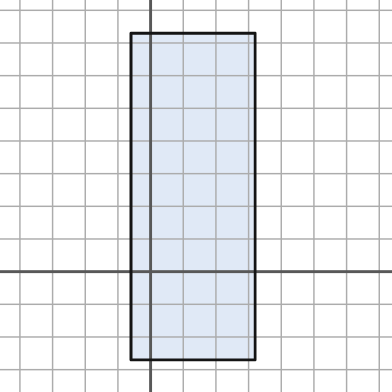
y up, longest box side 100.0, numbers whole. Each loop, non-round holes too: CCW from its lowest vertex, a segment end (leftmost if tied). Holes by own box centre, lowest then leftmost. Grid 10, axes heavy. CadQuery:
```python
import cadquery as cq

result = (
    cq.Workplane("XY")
    .moveTo(-6.0, -27.0)
    .lineTo(32.0, -27.0)
    .lineTo(32.0, 73.0)
    .lineTo(-6.0, 73.0)
    .close()
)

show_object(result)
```